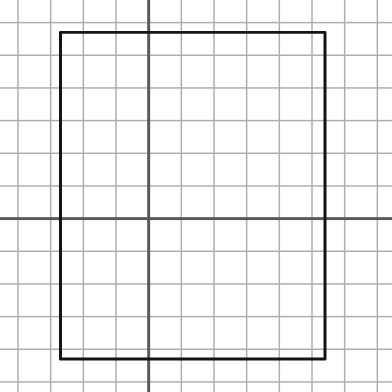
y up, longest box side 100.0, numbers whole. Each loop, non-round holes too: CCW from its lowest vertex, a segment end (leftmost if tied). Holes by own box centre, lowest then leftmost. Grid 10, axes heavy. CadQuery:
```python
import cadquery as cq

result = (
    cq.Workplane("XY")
    .moveTo(-27.0, -43.0)
    .lineTo(54.0, -43.0)
    .lineTo(54.0, 57.0)
    .lineTo(-27.0, 57.0)
    .close()
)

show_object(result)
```